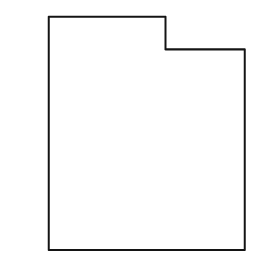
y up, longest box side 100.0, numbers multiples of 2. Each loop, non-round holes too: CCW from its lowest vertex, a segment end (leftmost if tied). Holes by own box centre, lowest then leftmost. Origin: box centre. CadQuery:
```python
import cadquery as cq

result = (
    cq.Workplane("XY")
    .moveTo(-42.0, -50.0)
    .lineTo(42.0, -50.0)
    .lineTo(42.0, 36.0)
    .lineTo(8.0, 36.0)
    .lineTo(8.0, 50.0)
    .lineTo(-42.0, 50.0)
    .close()
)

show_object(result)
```